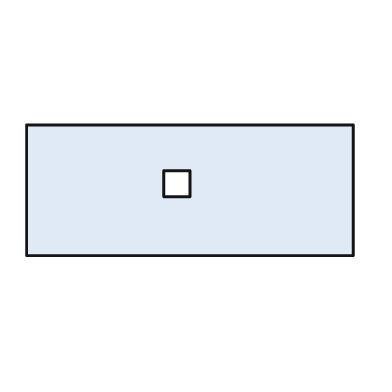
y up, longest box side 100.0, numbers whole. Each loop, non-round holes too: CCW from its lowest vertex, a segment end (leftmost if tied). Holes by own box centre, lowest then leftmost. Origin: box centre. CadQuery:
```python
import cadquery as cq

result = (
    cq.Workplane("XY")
    .moveTo(-50.0, -20.0)
    .lineTo(50.0, -20.0)
    .lineTo(50.0, 20.0)
    .lineTo(-50.0, 20.0)
    .close()
    .moveTo(-8.0, -2.0)
    .lineTo(0.0, -2.0)
    .lineTo(0.0, 6.0)
    .lineTo(-8.0, 6.0)
    .close()
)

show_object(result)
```